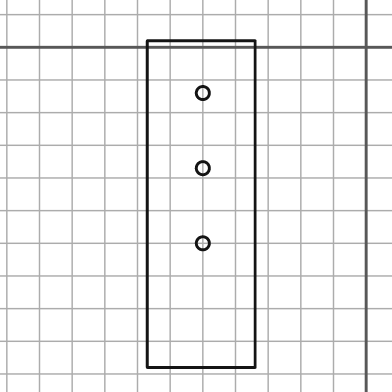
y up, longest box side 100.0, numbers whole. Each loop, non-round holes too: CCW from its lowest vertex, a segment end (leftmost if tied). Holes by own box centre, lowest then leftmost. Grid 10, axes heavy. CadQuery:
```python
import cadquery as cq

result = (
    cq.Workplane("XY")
    .moveTo(-67.0, -98.0)
    .lineTo(-34.0, -98.0)
    .lineTo(-34.0, 2.0)
    .lineTo(-67.0, 2.0)
    .close()
    .moveTo(-50.0, -60.0)
    .circle(2.0)
    .moveTo(-50.0, -37.0)
    .circle(2.0)
    .moveTo(-50.0, -14.0)
    .circle(2.0)
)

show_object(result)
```